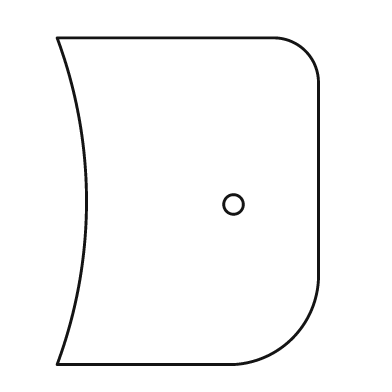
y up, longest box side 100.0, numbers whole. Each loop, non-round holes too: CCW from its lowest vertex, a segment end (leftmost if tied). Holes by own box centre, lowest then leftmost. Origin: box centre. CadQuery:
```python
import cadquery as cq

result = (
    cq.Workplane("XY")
    .moveTo(-40.0, -50.0)
    .lineTo(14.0, -50.0)
    .threePointArc((32.0, -42.0), (40.0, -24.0))
    .lineTo(40.0, 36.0)
    .threePointArc((36.0, 46.0), (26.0, 50.0))
    .lineTo(-40.0, 50.0)
    .threePointArc((-31.0, 0.0), (-40.0, -50.0))
    .close()
    .moveTo(14.0, -1.0)
    .circle(3.0)
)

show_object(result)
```